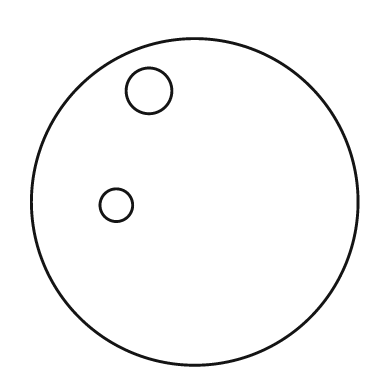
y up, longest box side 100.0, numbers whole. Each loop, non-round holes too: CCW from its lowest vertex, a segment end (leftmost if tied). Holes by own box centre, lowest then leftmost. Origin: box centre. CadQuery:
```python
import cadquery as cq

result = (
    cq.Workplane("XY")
    .moveTo(0.0, 0.0)
    .circle(50.0)
    .moveTo(-24.0, -1.0)
    .circle(5.0)
    .moveTo(-14.0, 34.0)
    .circle(7.0)
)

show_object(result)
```